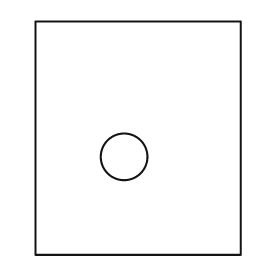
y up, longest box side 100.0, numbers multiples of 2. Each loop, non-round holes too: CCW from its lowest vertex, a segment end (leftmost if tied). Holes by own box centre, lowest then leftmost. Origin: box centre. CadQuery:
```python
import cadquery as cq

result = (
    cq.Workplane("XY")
    .moveTo(-44.0, -50.0)
    .lineTo(44.0, -50.0)
    .lineTo(44.0, 50.0)
    .lineTo(-44.0, 50.0)
    .close()
    .moveTo(-6.0, -8.0)
    .circle(10.0)
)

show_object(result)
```